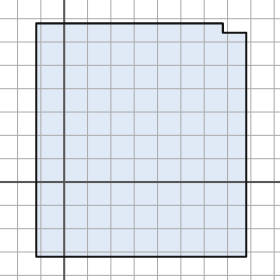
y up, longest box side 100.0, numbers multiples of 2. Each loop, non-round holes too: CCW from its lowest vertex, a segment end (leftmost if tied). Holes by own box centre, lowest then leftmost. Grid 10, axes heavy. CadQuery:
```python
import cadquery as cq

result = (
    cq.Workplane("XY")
    .moveTo(-12.0, -32.0)
    .lineTo(78.0, -32.0)
    .lineTo(78.0, 64.0)
    .lineTo(68.0, 64.0)
    .lineTo(68.0, 68.0)
    .lineTo(-12.0, 68.0)
    .close()
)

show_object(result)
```